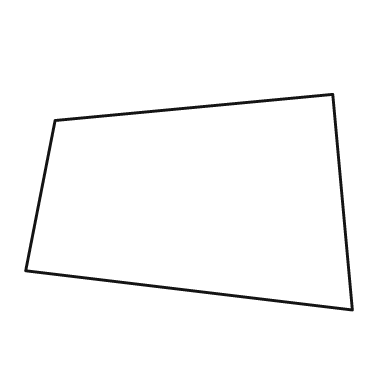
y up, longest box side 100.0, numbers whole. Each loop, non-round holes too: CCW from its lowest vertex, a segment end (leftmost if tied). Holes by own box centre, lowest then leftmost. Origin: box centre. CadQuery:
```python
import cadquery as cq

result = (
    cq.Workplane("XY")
    .moveTo(50.0, -33.0)
    .lineTo(44.0, 33.0)
    .lineTo(-41.0, 25.0)
    .lineTo(-50.0, -21.0)
    .close()
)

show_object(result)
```